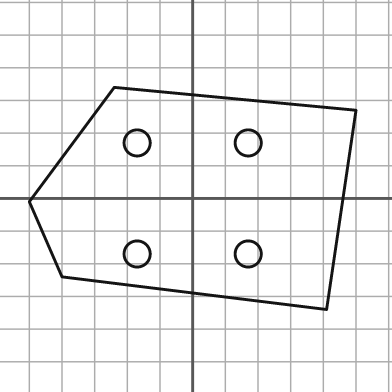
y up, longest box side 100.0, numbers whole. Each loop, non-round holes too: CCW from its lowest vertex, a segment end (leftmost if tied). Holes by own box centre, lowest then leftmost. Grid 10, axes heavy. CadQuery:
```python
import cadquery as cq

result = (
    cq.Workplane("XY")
    .moveTo(41.0, -34.0)
    .lineTo(50.0, 27.0)
    .lineTo(-24.0, 34.0)
    .lineTo(-50.0, -1.0)
    .lineTo(-40.0, -24.0)
    .close()
    .moveTo(-17.0, -17.0)
    .circle(4.0)
    .moveTo(17.0, -17.0)
    .circle(4.0)
    .moveTo(-17.0, 17.0)
    .circle(4.0)
    .moveTo(17.0, 17.0)
    .circle(4.0)
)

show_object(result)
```